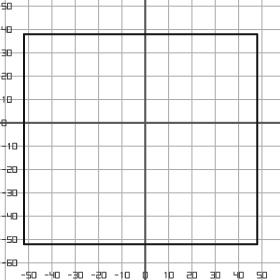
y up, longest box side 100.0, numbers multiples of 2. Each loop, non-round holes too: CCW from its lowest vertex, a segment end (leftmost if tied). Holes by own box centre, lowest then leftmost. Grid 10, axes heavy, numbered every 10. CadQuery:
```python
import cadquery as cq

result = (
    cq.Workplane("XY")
    .moveTo(-52.0, -52.0)
    .lineTo(48.0, -52.0)
    .lineTo(48.0, 38.0)
    .lineTo(-52.0, 38.0)
    .close()
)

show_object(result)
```